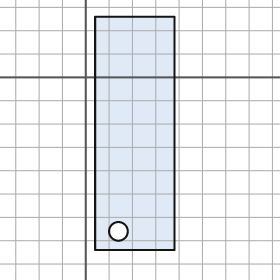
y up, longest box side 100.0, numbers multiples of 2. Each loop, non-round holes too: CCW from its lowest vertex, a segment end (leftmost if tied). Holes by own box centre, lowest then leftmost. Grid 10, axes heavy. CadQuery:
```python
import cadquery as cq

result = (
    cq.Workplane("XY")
    .moveTo(4.0, -74.0)
    .lineTo(38.0, -74.0)
    .lineTo(38.0, 26.0)
    .lineTo(4.0, 26.0)
    .close()
    .moveTo(14.0, -66.0)
    .circle(4.0)
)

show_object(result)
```